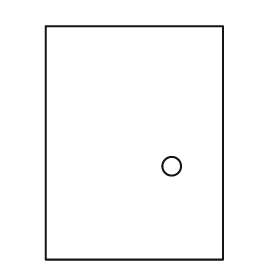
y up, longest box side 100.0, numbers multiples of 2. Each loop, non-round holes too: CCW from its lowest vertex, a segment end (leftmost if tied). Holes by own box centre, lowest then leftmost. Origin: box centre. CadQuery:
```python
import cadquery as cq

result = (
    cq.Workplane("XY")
    .moveTo(-38.0, -50.0)
    .lineTo(38.0, -50.0)
    .lineTo(38.0, 50.0)
    .lineTo(-38.0, 50.0)
    .close()
    .moveTo(16.0, -10.0)
    .circle(4.0)
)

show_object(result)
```